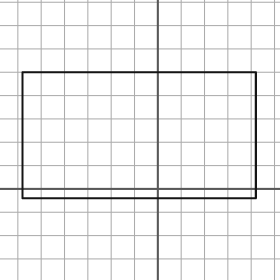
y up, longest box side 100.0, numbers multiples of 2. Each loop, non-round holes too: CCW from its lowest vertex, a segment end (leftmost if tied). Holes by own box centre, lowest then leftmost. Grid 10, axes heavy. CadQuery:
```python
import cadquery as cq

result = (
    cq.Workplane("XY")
    .moveTo(-58.0, -4.0)
    .lineTo(42.0, -4.0)
    .lineTo(42.0, 50.0)
    .lineTo(-58.0, 50.0)
    .close()
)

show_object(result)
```